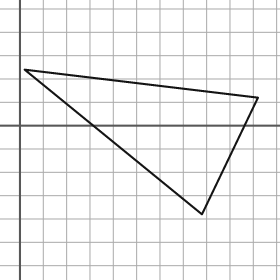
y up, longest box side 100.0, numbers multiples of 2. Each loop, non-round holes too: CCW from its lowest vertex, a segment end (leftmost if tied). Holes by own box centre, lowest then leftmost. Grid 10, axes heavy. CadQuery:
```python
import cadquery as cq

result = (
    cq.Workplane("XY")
    .moveTo(78.0, -38.0)
    .lineTo(102.0, 12.0)
    .lineTo(2.0, 24.0)
    .close()
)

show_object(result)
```